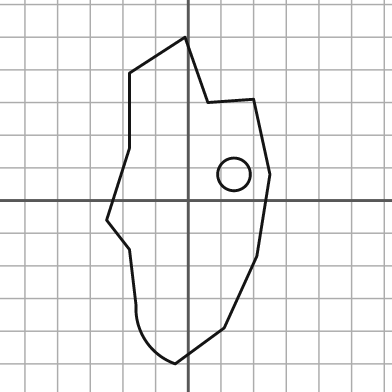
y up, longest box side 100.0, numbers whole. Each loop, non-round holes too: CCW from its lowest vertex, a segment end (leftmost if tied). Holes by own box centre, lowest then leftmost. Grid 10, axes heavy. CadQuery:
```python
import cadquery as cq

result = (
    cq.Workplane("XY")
    .moveTo(-4.0, -50.0)
    .lineTo(11.0, -39.0)
    .lineTo(21.0, -17.0)
    .lineTo(25.0, 8.0)
    .lineTo(20.0, 31.0)
    .lineTo(6.0, 30.0)
    .lineTo(-1.0, 50.0)
    .lineTo(-18.0, 39.0)
    .lineTo(-18.0, 16.0)
    .lineTo(-25.0, -6.0)
    .lineTo(-18.0, -15.0)
    .lineTo(-16.0, -32.0)
    .threePointArc((-13.0, -43.0), (-4.0, -50.0))
    .close()
    .moveTo(14.0, 8.0)
    .circle(5.0)
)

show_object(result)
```